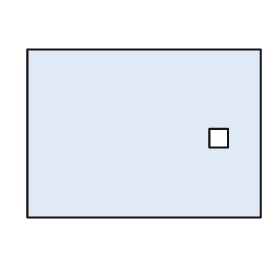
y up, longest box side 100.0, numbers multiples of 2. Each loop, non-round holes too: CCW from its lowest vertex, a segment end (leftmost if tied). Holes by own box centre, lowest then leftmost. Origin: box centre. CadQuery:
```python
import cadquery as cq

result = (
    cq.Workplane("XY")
    .moveTo(-50.0, -36.0)
    .lineTo(50.0, -36.0)
    .lineTo(50.0, 36.0)
    .lineTo(-50.0, 36.0)
    .close()
    .moveTo(28.0, -6.0)
    .lineTo(36.0, -6.0)
    .lineTo(36.0, 2.0)
    .lineTo(28.0, 2.0)
    .close()
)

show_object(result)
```